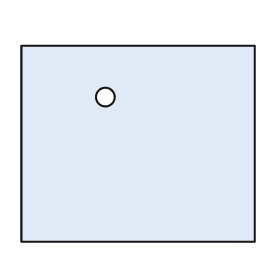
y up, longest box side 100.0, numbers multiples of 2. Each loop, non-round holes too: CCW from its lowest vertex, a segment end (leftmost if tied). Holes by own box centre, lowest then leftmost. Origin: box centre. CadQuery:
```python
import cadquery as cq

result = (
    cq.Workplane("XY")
    .moveTo(-50.0, -42.0)
    .lineTo(50.0, -42.0)
    .lineTo(50.0, 42.0)
    .lineTo(-50.0, 42.0)
    .close()
    .moveTo(-14.0, 20.0)
    .circle(4.0)
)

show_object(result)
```